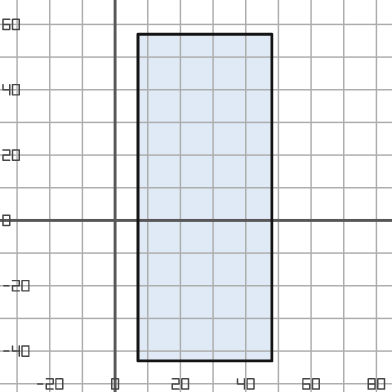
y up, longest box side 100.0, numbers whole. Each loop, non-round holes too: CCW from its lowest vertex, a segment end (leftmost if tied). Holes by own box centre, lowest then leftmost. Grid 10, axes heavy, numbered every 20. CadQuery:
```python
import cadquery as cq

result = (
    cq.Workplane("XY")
    .moveTo(7.0, -43.0)
    .lineTo(48.0, -43.0)
    .lineTo(48.0, 57.0)
    .lineTo(7.0, 57.0)
    .close()
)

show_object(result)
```